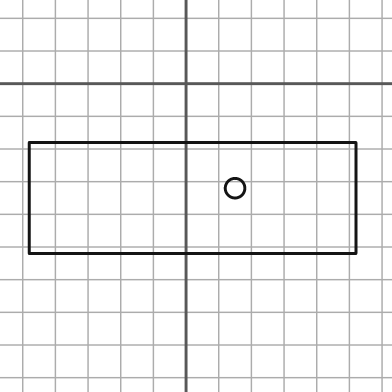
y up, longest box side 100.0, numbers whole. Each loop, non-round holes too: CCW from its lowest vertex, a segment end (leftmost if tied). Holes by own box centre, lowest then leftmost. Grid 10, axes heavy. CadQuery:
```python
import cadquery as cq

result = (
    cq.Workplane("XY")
    .moveTo(-48.0, -52.0)
    .lineTo(52.0, -52.0)
    .lineTo(52.0, -18.0)
    .lineTo(-48.0, -18.0)
    .close()
    .moveTo(15.0, -32.0)
    .circle(3.0)
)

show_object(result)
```